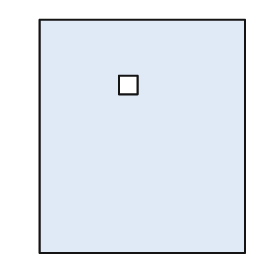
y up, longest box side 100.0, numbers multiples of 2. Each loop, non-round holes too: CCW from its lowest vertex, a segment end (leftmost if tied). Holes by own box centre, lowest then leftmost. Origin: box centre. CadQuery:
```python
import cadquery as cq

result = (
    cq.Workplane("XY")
    .moveTo(-44.0, -50.0)
    .lineTo(44.0, -50.0)
    .lineTo(44.0, 50.0)
    .lineTo(-44.0, 50.0)
    .close()
    .moveTo(-10.0, 18.0)
    .lineTo(-2.0, 18.0)
    .lineTo(-2.0, 26.0)
    .lineTo(-10.0, 26.0)
    .close()
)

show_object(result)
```